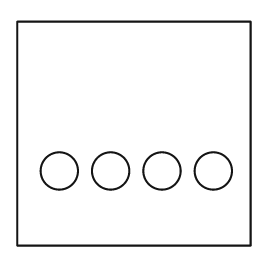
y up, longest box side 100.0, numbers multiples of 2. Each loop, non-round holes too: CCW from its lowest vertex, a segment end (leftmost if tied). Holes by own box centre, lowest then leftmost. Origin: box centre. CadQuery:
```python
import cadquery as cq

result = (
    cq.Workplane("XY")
    .moveTo(-50.0, -48.0)
    .lineTo(50.0, -48.0)
    .lineTo(50.0, 48.0)
    .lineTo(-50.0, 48.0)
    .close()
    .moveTo(-32.0, -16.0)
    .circle(8.0)
    .moveTo(-10.0, -16.0)
    .circle(8.0)
    .moveTo(12.0, -16.0)
    .circle(8.0)
    .moveTo(34.0, -16.0)
    .circle(8.0)
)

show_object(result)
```